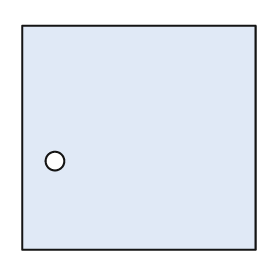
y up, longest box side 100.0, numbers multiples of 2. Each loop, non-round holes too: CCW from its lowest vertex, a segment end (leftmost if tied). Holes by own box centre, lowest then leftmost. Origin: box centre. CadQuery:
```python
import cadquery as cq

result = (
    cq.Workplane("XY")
    .moveTo(-50.0, -48.0)
    .lineTo(50.0, -48.0)
    .lineTo(50.0, 48.0)
    .lineTo(-50.0, 48.0)
    .close()
    .moveTo(-36.0, -10.0)
    .circle(4.0)
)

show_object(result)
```